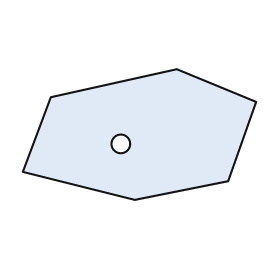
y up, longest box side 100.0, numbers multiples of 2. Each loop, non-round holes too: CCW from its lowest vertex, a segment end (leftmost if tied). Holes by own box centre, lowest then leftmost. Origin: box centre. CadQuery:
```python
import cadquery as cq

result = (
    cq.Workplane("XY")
    .moveTo(-2.0, -28.0)
    .lineTo(38.0, -20.0)
    .lineTo(50.0, 14.0)
    .lineTo(16.0, 28.0)
    .lineTo(-38.0, 16.0)
    .lineTo(-50.0, -16.0)
    .close()
    .moveTo(-8.0, -4.0)
    .circle(4.0)
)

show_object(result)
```